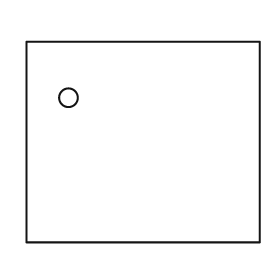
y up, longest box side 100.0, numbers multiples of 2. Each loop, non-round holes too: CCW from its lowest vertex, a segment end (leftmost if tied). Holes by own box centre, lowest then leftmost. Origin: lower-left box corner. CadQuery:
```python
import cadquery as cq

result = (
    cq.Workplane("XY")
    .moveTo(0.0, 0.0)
    .lineTo(100.0, 0.0)
    .lineTo(100.0, 86.0)
    .lineTo(0.0, 86.0)
    .close()
    .moveTo(18.0, 62.0)
    .circle(4.0)
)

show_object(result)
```